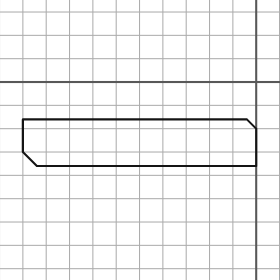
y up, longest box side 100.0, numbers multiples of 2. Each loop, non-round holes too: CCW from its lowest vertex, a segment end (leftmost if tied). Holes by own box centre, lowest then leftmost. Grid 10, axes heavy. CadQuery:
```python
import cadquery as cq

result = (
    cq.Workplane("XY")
    .moveTo(-94.0, -36.0)
    .lineTo(0.0, -36.0)
    .lineTo(0.0, -20.0)
    .lineTo(-4.0, -16.0)
    .lineTo(-100.0, -16.0)
    .lineTo(-100.0, -30.0)
    .close()
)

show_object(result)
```